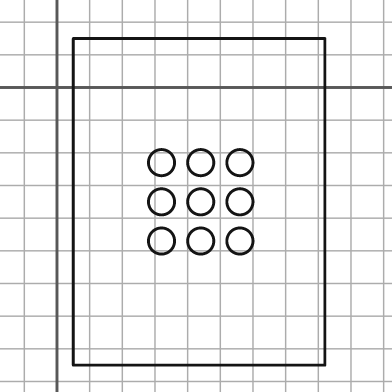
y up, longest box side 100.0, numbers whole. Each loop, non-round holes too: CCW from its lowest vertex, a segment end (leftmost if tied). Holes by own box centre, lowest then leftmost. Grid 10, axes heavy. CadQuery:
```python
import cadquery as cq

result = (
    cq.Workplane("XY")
    .moveTo(5.0, -85.0)
    .lineTo(82.0, -85.0)
    .lineTo(82.0, 15.0)
    .lineTo(5.0, 15.0)
    .close()
    .moveTo(32.0, -47.0)
    .circle(4.0)
    .moveTo(44.0, -47.0)
    .circle(4.0)
    .moveTo(56.0, -47.0)
    .circle(4.0)
    .moveTo(32.0, -35.0)
    .circle(4.0)
    .moveTo(44.0, -35.0)
    .circle(4.0)
    .moveTo(56.0, -35.0)
    .circle(4.0)
    .moveTo(32.0, -23.0)
    .circle(4.0)
    .moveTo(44.0, -23.0)
    .circle(4.0)
    .moveTo(56.0, -23.0)
    .circle(4.0)
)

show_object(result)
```